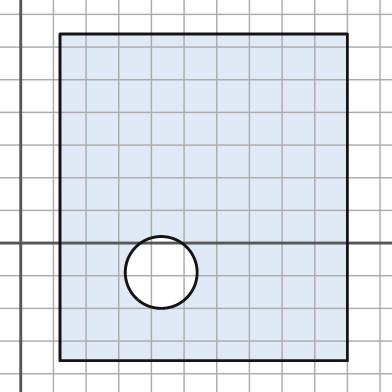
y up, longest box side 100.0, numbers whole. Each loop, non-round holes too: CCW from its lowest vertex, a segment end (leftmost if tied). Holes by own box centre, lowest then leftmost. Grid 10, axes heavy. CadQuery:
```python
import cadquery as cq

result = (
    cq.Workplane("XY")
    .moveTo(12.0, -36.0)
    .lineTo(100.0, -36.0)
    .lineTo(100.0, 64.0)
    .lineTo(12.0, 64.0)
    .close()
    .moveTo(43.0, -9.0)
    .circle(11.0)
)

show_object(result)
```